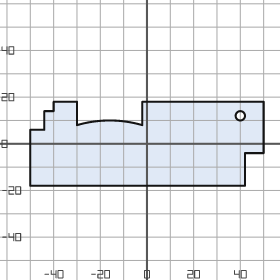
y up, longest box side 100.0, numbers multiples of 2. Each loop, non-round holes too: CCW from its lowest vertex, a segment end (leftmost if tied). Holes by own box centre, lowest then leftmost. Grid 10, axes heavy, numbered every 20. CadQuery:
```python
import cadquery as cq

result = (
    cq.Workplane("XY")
    .moveTo(-50.0, -18.0)
    .lineTo(42.0, -18.0)
    .lineTo(42.0, -4.0)
    .lineTo(50.0, -4.0)
    .lineTo(50.0, 18.0)
    .lineTo(-2.0, 18.0)
    .lineTo(-2.0, 8.0)
    .threePointArc((-16.0, 10.0), (-30.0, 8.0))
    .lineTo(-30.0, 18.0)
    .lineTo(-40.0, 18.0)
    .lineTo(-40.0, 14.0)
    .lineTo(-44.0, 14.0)
    .lineTo(-44.0, 6.0)
    .lineTo(-50.0, 6.0)
    .close()
    .moveTo(40.0, 12.0)
    .circle(2.0)
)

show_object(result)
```